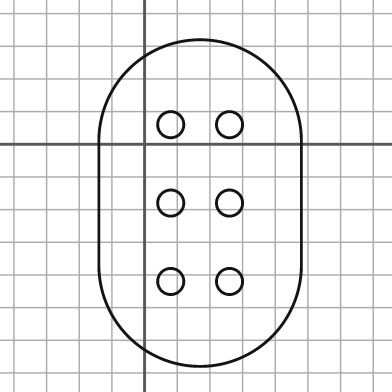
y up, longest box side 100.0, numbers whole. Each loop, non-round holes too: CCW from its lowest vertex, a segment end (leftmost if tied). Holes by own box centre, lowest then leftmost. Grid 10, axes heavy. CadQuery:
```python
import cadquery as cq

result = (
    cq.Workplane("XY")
    .moveTo(-14.0, -37.0)
    .threePointArc((17.0, -68.0), (48.0, -37.0))
    .lineTo(48.0, 1.0)
    .threePointArc((17.0, 32.0), (-14.0, 1.0))
    .close()
    .moveTo(8.0, -42.0)
    .circle(4.0)
    .moveTo(26.0, -42.0)
    .circle(4.0)
    .moveTo(8.0, -18.0)
    .circle(4.0)
    .moveTo(26.0, -18.0)
    .circle(4.0)
    .moveTo(8.0, 6.0)
    .circle(4.0)
    .moveTo(26.0, 6.0)
    .circle(4.0)
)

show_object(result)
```